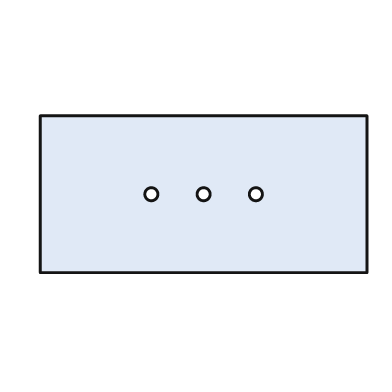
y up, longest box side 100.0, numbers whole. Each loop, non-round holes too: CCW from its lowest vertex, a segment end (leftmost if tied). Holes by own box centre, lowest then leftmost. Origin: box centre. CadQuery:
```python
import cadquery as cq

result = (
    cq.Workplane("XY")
    .moveTo(-50.0, -24.0)
    .lineTo(50.0, -24.0)
    .lineTo(50.0, 24.0)
    .lineTo(-50.0, 24.0)
    .close()
    .moveTo(-16.0, 0.0)
    .circle(2.0)
    .moveTo(0.0, 0.0)
    .circle(2.0)
    .moveTo(16.0, 0.0)
    .circle(2.0)
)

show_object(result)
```